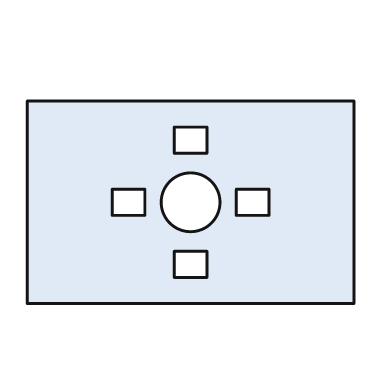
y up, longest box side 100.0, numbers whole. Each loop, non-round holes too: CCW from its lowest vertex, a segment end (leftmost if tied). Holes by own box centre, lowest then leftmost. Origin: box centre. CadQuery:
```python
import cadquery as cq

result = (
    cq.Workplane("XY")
    .moveTo(-50.0, -31.0)
    .lineTo(50.0, -31.0)
    .lineTo(50.0, 31.0)
    .lineTo(-50.0, 31.0)
    .close()
    .moveTo(-5.0, -23.0)
    .lineTo(5.0, -23.0)
    .lineTo(5.0, -15.0)
    .lineTo(-5.0, -15.0)
    .close()
    .moveTo(-24.0, -4.0)
    .lineTo(-14.0, -4.0)
    .lineTo(-14.0, 4.0)
    .lineTo(-24.0, 4.0)
    .close()
    .moveTo(0.0, 0.0)
    .circle(9.0)
    .moveTo(14.0, -4.0)
    .lineTo(24.0, -4.0)
    .lineTo(24.0, 4.0)
    .lineTo(14.0, 4.0)
    .close()
    .moveTo(-5.0, 15.0)
    .lineTo(5.0, 15.0)
    .lineTo(5.0, 23.0)
    .lineTo(-5.0, 23.0)
    .close()
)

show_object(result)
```